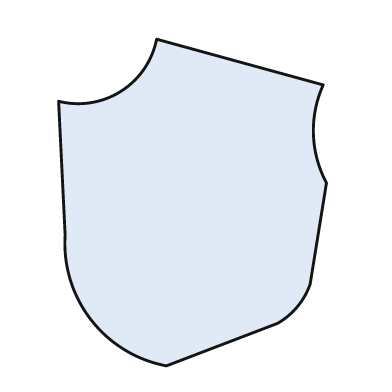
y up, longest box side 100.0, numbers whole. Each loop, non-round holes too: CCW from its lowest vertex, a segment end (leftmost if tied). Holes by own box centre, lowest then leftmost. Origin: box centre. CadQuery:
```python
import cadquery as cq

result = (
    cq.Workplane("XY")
    .moveTo(-8.0, -50.0)
    .lineTo(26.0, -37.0)
    .threePointArc((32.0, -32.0), (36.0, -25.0))
    .lineTo(41.0, 6.0)
    .threePointArc((37.0, 21.0), (40.0, 36.0))
    .lineTo(-11.0, 50.0)
    .threePointArc((-22.0, 34.0), (-41.0, 31.0))
    .lineTo(-39.0, -10.0)
    .threePointArc((-31.0, -36.0), (-8.0, -50.0))
    .close()
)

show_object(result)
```